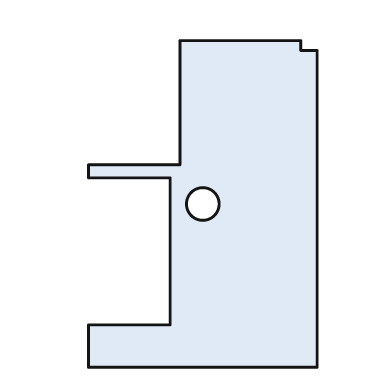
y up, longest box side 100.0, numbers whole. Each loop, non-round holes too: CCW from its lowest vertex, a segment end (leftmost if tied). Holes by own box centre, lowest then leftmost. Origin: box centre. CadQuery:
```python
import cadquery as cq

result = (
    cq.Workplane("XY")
    .moveTo(-35.0, -50.0)
    .lineTo(35.0, -50.0)
    .lineTo(35.0, 47.0)
    .lineTo(30.0, 47.0)
    .lineTo(30.0, 50.0)
    .lineTo(-7.0, 50.0)
    .lineTo(-7.0, 12.0)
    .lineTo(-35.0, 12.0)
    .lineTo(-35.0, 8.0)
    .lineTo(-10.0, 8.0)
    .lineTo(-10.0, -37.0)
    .lineTo(-35.0, -37.0)
    .close()
    .moveTo(0.0, 0.0)
    .circle(5.0)
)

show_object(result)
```